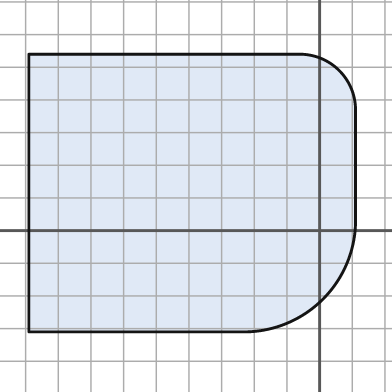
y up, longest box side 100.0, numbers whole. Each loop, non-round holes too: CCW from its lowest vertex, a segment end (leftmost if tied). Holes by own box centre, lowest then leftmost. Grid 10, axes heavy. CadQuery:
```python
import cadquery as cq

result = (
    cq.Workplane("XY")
    .moveTo(-89.0, -31.0)
    .lineTo(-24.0, -31.0)
    .threePointArc((1.0, -21.0), (11.0, 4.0))
    .lineTo(11.0, 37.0)
    .threePointArc((6.0, 49.0), (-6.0, 54.0))
    .lineTo(-89.0, 54.0)
    .close()
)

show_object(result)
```